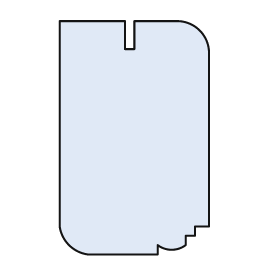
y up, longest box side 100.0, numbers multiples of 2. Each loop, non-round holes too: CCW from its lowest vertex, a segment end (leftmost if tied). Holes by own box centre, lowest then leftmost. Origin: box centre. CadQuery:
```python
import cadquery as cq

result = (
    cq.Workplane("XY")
    .moveTo(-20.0, -50.0)
    .lineTo(10.0, -50.0)
    .lineTo(10.0, -46.0)
    .threePointArc((16.0, -48.0), (22.0, -46.0))
    .lineTo(22.0, -42.0)
    .lineTo(26.0, -42.0)
    .lineTo(26.0, -38.0)
    .lineTo(32.0, -38.0)
    .lineTo(32.0, 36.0)
    .threePointArc((28.0, 46.0), (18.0, 50.0))
    .lineTo(0.0, 50.0)
    .lineTo(0.0, 38.0)
    .lineTo(-4.0, 38.0)
    .lineTo(-4.0, 50.0)
    .lineTo(-32.0, 50.0)
    .lineTo(-32.0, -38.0)
    .threePointArc((-28.0, -46.0), (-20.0, -50.0))
    .close()
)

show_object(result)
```